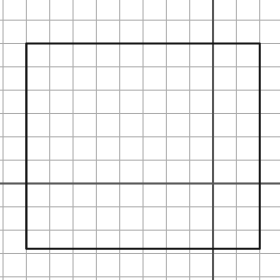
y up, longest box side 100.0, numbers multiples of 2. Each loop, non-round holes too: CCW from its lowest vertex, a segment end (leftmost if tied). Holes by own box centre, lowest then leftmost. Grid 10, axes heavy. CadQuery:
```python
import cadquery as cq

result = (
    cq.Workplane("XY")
    .moveTo(-80.0, -28.0)
    .lineTo(20.0, -28.0)
    .lineTo(20.0, 60.0)
    .lineTo(-80.0, 60.0)
    .close()
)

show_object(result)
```